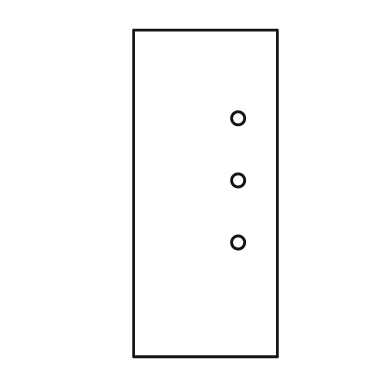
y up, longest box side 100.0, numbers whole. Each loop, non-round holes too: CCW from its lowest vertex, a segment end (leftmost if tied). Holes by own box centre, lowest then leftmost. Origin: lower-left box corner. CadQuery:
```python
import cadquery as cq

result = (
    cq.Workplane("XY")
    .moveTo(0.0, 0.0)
    .lineTo(44.0, 0.0)
    .lineTo(44.0, 100.0)
    .lineTo(0.0, 100.0)
    .close()
    .moveTo(32.0, 35.0)
    .circle(2.0)
    .moveTo(32.0, 54.0)
    .circle(2.0)
    .moveTo(32.0, 73.0)
    .circle(2.0)
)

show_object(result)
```